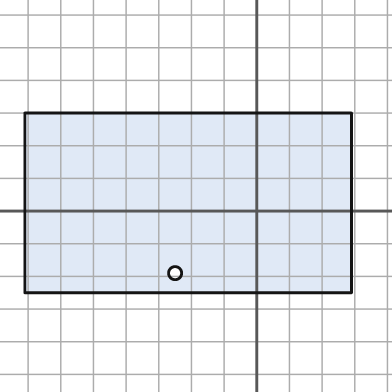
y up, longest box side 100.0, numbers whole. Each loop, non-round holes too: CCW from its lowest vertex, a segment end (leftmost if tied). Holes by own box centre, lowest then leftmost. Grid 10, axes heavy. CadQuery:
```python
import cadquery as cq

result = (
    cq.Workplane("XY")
    .moveTo(-71.0, -25.0)
    .lineTo(29.0, -25.0)
    .lineTo(29.0, 30.0)
    .lineTo(-71.0, 30.0)
    .close()
    .moveTo(-25.0, -19.0)
    .circle(2.0)
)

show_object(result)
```